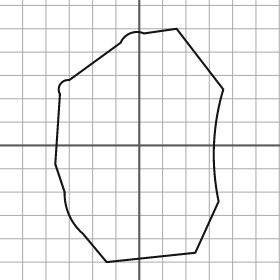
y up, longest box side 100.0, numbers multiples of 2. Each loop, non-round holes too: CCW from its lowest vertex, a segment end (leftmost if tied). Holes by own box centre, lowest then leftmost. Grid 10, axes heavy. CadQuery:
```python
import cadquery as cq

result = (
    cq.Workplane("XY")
    .moveTo(-14.0, -50.0)
    .lineTo(24.0, -46.0)
    .lineTo(34.0, -24.0)
    .threePointArc((32.0, 0.0), (36.0, 24.0))
    .lineTo(16.0, 50.0)
    .lineTo(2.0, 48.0)
    .threePointArc((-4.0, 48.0), (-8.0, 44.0))
    .lineTo(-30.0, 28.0)
    .threePointArc((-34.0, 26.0), (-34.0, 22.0))
    .lineTo(-36.0, -8.0)
    .lineTo(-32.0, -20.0)
    .threePointArc((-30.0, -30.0), (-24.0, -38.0))
    .close()
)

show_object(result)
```